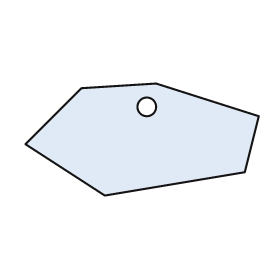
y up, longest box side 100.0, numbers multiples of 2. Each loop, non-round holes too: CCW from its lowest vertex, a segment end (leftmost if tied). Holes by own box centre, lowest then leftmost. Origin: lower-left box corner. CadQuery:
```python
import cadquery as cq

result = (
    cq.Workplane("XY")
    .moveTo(34.0, 0.0)
    .lineTo(94.0, 10.0)
    .lineTo(100.0, 34.0)
    .lineTo(56.0, 48.0)
    .lineTo(24.0, 46.0)
    .lineTo(0.0, 22.0)
    .close()
    .moveTo(52.0, 38.0)
    .circle(4.0)
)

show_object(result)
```